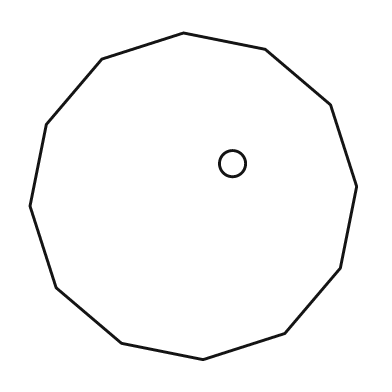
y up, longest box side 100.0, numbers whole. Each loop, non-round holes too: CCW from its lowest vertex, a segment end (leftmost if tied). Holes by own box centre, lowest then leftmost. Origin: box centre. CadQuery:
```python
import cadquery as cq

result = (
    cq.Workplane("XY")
    .moveTo(3.0, -50.0)
    .lineTo(28.0, -42.0)
    .lineTo(45.0, -22.0)
    .lineTo(50.0, 3.0)
    .lineTo(42.0, 28.0)
    .lineTo(22.0, 45.0)
    .lineTo(-3.0, 50.0)
    .lineTo(-28.0, 42.0)
    .lineTo(-45.0, 22.0)
    .lineTo(-50.0, -3.0)
    .lineTo(-42.0, -28.0)
    .lineTo(-22.0, -45.0)
    .close()
    .moveTo(12.0, 10.0)
    .circle(4.0)
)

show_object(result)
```